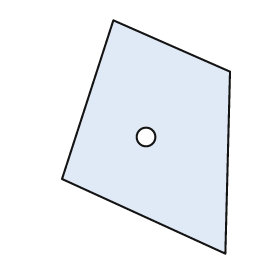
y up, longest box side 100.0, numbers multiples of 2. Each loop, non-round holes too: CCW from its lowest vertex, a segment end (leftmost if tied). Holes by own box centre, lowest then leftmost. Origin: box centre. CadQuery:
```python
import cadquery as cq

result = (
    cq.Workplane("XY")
    .moveTo(34.0, -50.0)
    .lineTo(36.0, 28.0)
    .lineTo(-14.0, 50.0)
    .lineTo(-36.0, -18.0)
    .close()
    .moveTo(0.0, 0.0)
    .circle(4.0)
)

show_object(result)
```